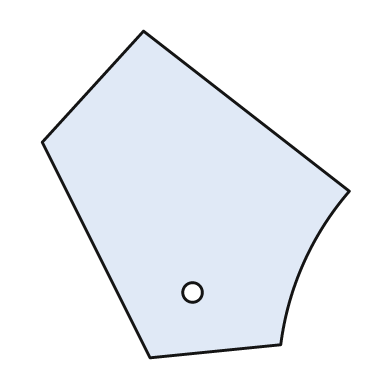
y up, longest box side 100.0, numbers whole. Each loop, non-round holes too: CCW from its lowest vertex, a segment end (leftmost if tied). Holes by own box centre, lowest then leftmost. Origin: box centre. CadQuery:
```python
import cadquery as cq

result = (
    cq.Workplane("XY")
    .moveTo(-14.0, -50.0)
    .lineTo(26.0, -46.0)
    .threePointArc((33.0, -21.0), (47.0, 1.0))
    .lineTo(-16.0, 50.0)
    .lineTo(-47.0, 16.0)
    .close()
    .moveTo(-1.0, -30.0)
    .circle(3.0)
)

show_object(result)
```